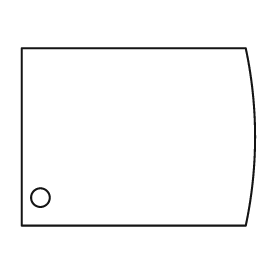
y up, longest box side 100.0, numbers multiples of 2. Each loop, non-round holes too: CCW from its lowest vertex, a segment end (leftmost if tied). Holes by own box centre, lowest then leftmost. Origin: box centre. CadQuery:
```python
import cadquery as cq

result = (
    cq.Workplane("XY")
    .moveTo(-50.0, -38.0)
    .lineTo(46.0, -38.0)
    .threePointArc((50.0, 0.0), (46.0, 38.0))
    .lineTo(-50.0, 38.0)
    .close()
    .moveTo(-42.0, -26.0)
    .circle(4.0)
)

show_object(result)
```